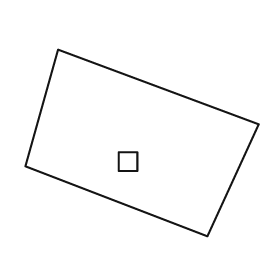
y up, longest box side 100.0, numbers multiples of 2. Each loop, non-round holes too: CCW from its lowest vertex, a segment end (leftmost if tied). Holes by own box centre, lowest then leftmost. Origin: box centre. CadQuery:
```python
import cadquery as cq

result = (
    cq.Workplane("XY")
    .moveTo(28.0, -40.0)
    .lineTo(50.0, 8.0)
    .lineTo(-36.0, 40.0)
    .lineTo(-50.0, -10.0)
    .close()
    .moveTo(-10.0, -12.0)
    .lineTo(-2.0, -12.0)
    .lineTo(-2.0, -4.0)
    .lineTo(-10.0, -4.0)
    .close()
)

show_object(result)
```